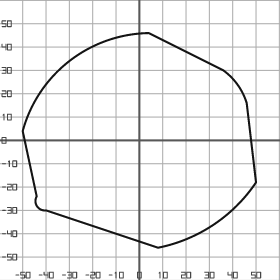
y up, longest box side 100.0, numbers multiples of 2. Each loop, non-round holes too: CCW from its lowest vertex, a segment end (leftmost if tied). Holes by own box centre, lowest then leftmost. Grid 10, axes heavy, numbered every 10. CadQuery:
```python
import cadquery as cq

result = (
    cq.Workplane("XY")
    .moveTo(8.0, -46.0)
    .threePointArc((32.0, -36.0), (50.0, -18.0))
    .lineTo(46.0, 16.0)
    .threePointArc((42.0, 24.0), (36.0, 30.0))
    .lineTo(4.0, 46.0)
    .threePointArc((-30.0, 34.0), (-50.0, 4.0))
    .lineTo(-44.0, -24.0)
    .threePointArc((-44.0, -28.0), (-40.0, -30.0))
    .close()
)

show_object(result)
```